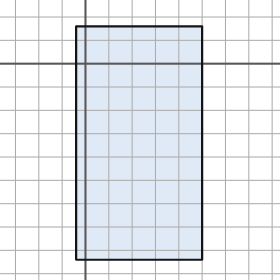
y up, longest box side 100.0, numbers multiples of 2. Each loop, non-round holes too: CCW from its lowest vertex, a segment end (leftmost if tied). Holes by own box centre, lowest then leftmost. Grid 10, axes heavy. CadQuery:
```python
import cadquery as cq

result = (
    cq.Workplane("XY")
    .moveTo(-4.0, -84.0)
    .lineTo(50.0, -84.0)
    .lineTo(50.0, 16.0)
    .lineTo(-4.0, 16.0)
    .close()
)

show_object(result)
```